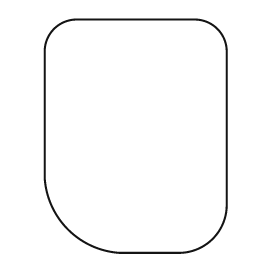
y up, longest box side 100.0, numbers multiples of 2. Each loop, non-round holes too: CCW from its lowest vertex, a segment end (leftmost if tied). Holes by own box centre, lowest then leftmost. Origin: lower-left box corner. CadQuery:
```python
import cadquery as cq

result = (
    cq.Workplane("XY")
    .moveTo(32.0, 0.0)
    .lineTo(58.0, 0.0)
    .threePointArc((72.0, 6.0), (78.0, 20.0))
    .lineTo(78.0, 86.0)
    .threePointArc((74.0, 96.0), (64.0, 100.0))
    .lineTo(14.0, 100.0)
    .threePointArc((4.0, 96.0), (0.0, 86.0))
    .lineTo(0.0, 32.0)
    .threePointArc((10.0, 10.0), (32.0, 0.0))
    .close()
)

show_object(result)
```